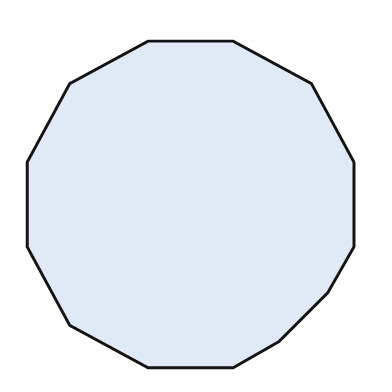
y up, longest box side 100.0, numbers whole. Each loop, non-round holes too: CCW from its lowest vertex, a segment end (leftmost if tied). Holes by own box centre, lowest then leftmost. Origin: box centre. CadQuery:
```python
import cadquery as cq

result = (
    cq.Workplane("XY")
    .moveTo(-13.0, -50.0)
    .lineTo(13.0, -50.0)
    .lineTo(27.0, -42.0)
    .lineTo(42.0, -27.0)
    .lineTo(50.0, -13.0)
    .lineTo(50.0, 13.0)
    .lineTo(37.0, 37.0)
    .lineTo(13.0, 50.0)
    .lineTo(-13.0, 50.0)
    .lineTo(-37.0, 37.0)
    .lineTo(-50.0, 13.0)
    .lineTo(-50.0, -13.0)
    .lineTo(-37.0, -37.0)
    .close()
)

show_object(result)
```